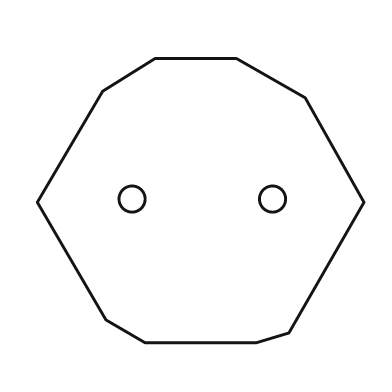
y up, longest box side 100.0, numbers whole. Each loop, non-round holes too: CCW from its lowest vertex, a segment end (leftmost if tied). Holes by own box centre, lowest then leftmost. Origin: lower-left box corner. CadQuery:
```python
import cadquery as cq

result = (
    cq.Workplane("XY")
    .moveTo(33.0, 0.0)
    .lineTo(67.0, 0.0)
    .lineTo(77.0, 3.0)
    .lineTo(100.0, 43.0)
    .lineTo(82.0, 75.0)
    .lineTo(61.0, 87.0)
    .lineTo(36.0, 87.0)
    .lineTo(20.0, 77.0)
    .lineTo(0.0, 43.0)
    .lineTo(21.0, 7.0)
    .close()
    .moveTo(29.0, 44.0)
    .circle(4.0)
    .moveTo(72.0, 44.0)
    .circle(4.0)
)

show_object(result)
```